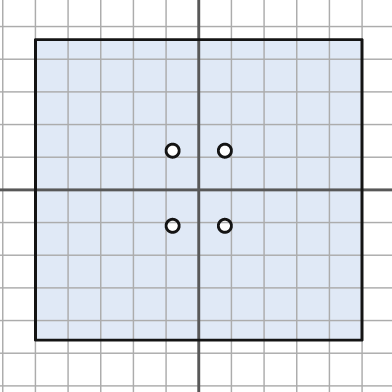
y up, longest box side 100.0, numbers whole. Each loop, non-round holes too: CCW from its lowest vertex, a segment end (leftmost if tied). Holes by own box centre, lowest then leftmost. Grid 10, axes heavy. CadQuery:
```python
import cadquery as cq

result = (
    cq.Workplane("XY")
    .moveTo(-50.0, -46.0)
    .lineTo(50.0, -46.0)
    .lineTo(50.0, 46.0)
    .lineTo(-50.0, 46.0)
    .close()
    .moveTo(-8.0, -11.0)
    .circle(2.0)
    .moveTo(8.0, -11.0)
    .circle(2.0)
    .moveTo(-8.0, 12.0)
    .circle(2.0)
    .moveTo(8.0, 12.0)
    .circle(2.0)
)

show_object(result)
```